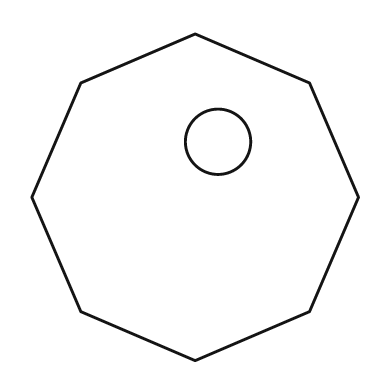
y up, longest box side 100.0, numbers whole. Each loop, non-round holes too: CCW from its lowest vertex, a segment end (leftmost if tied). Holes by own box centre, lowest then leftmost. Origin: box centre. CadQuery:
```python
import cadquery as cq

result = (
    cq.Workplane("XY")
    .moveTo(0.0, -50.0)
    .lineTo(35.0, -35.0)
    .lineTo(50.0, 0.0)
    .lineTo(35.0, 35.0)
    .lineTo(0.0, 50.0)
    .lineTo(-35.0, 35.0)
    .lineTo(-50.0, 0.0)
    .lineTo(-35.0, -35.0)
    .close()
    .moveTo(7.0, 17.0)
    .circle(10.0)
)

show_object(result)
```